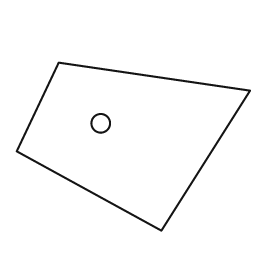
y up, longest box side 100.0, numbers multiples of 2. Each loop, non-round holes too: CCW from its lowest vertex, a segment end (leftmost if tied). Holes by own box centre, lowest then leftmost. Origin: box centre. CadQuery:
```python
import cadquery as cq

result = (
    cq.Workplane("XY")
    .moveTo(12.0, -36.0)
    .lineTo(50.0, 24.0)
    .lineTo(-32.0, 36.0)
    .lineTo(-50.0, -2.0)
    .close()
    .moveTo(-14.0, 10.0)
    .circle(4.0)
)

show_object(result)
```